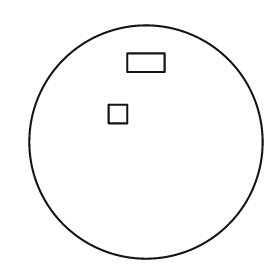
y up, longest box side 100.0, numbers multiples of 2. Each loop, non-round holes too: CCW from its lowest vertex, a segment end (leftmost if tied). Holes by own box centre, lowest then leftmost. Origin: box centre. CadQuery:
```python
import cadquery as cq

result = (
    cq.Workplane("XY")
    .moveTo(0.0, 0.0)
    .circle(50.0)
    .moveTo(-16.0, 8.0)
    .lineTo(-8.0, 8.0)
    .lineTo(-8.0, 16.0)
    .lineTo(-16.0, 16.0)
    .close()
    .moveTo(-8.0, 30.0)
    .lineTo(8.0, 30.0)
    .lineTo(8.0, 38.0)
    .lineTo(-8.0, 38.0)
    .close()
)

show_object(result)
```